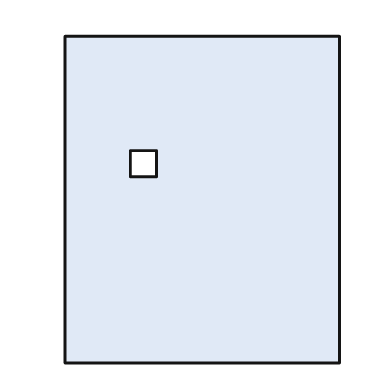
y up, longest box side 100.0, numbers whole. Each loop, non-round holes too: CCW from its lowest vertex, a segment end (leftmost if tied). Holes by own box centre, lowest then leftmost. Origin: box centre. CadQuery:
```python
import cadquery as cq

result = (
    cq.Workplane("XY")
    .moveTo(-42.0, -50.0)
    .lineTo(42.0, -50.0)
    .lineTo(42.0, 50.0)
    .lineTo(-42.0, 50.0)
    .close()
    .moveTo(-22.0, 7.0)
    .lineTo(-14.0, 7.0)
    .lineTo(-14.0, 15.0)
    .lineTo(-22.0, 15.0)
    .close()
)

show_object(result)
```